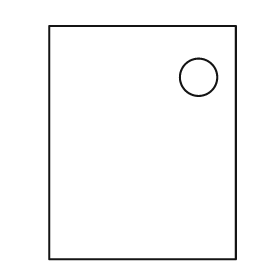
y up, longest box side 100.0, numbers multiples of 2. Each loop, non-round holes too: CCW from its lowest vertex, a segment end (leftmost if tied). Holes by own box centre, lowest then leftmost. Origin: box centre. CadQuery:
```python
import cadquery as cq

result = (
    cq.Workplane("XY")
    .moveTo(-40.0, -50.0)
    .lineTo(40.0, -50.0)
    .lineTo(40.0, 50.0)
    .lineTo(-40.0, 50.0)
    .close()
    .moveTo(24.0, 28.0)
    .circle(8.0)
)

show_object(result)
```